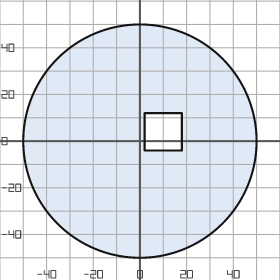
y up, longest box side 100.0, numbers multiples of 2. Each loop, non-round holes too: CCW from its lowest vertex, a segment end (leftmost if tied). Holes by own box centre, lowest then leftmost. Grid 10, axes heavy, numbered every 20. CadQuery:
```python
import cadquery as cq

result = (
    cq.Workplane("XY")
    .moveTo(0.0, 0.0)
    .circle(50.0)
    .moveTo(2.0, -4.0)
    .lineTo(18.0, -4.0)
    .lineTo(18.0, 12.0)
    .lineTo(2.0, 12.0)
    .close()
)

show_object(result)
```